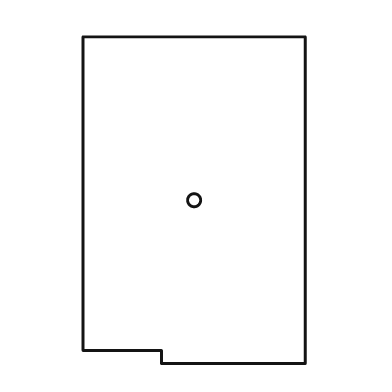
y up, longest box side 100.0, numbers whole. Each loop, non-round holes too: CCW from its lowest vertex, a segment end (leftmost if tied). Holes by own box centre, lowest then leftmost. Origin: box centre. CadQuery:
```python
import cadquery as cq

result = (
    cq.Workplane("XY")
    .moveTo(-10.0, -50.0)
    .lineTo(34.0, -50.0)
    .lineTo(34.0, 50.0)
    .lineTo(-34.0, 50.0)
    .lineTo(-34.0, -46.0)
    .lineTo(-10.0, -46.0)
    .close()
    .moveTo(0.0, 0.0)
    .circle(2.0)
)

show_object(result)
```